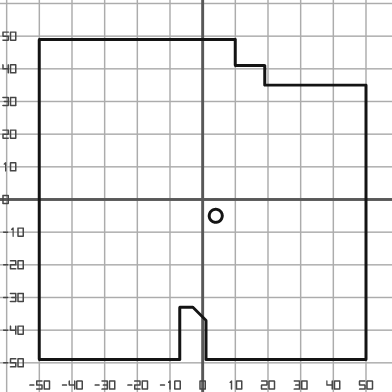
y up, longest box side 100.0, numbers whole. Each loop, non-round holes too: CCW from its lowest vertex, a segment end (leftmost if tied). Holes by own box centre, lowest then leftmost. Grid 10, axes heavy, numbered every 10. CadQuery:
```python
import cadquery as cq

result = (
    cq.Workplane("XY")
    .moveTo(-50.0, -49.0)
    .lineTo(-7.0, -49.0)
    .lineTo(-7.0, -33.0)
    .lineTo(-3.0, -33.0)
    .lineTo(1.0, -37.0)
    .lineTo(1.0, -49.0)
    .lineTo(50.0, -49.0)
    .lineTo(50.0, 35.0)
    .lineTo(19.0, 35.0)
    .lineTo(19.0, 41.0)
    .lineTo(10.0, 41.0)
    .lineTo(10.0, 49.0)
    .lineTo(-50.0, 49.0)
    .close()
    .moveTo(4.0, -5.0)
    .circle(2.0)
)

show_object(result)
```